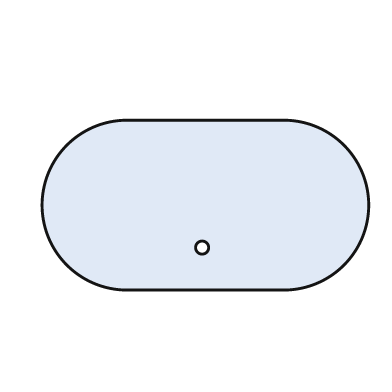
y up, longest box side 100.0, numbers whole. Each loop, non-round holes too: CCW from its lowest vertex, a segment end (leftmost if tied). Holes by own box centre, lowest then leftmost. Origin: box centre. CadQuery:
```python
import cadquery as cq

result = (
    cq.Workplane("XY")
    .moveTo(-24.0, -26.0)
    .lineTo(24.0, -26.0)
    .threePointArc((50.0, 0.0), (24.0, 26.0))
    .lineTo(-24.0, 26.0)
    .threePointArc((-50.0, 0.0), (-24.0, -26.0))
    .close()
    .moveTo(-1.0, -13.0)
    .circle(2.0)
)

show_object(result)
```